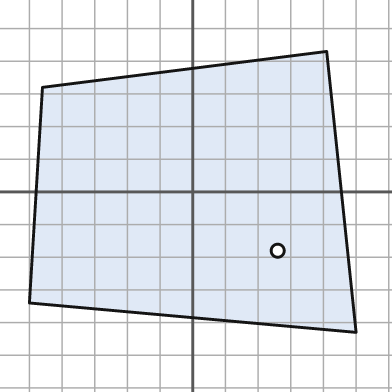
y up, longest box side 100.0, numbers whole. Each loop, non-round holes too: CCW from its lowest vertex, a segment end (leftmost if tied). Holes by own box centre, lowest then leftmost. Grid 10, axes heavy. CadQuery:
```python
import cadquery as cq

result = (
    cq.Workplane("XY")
    .moveTo(50.0, -43.0)
    .lineTo(41.0, 43.0)
    .lineTo(-46.0, 32.0)
    .lineTo(-50.0, -34.0)
    .close()
    .moveTo(26.0, -18.0)
    .circle(2.0)
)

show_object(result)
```